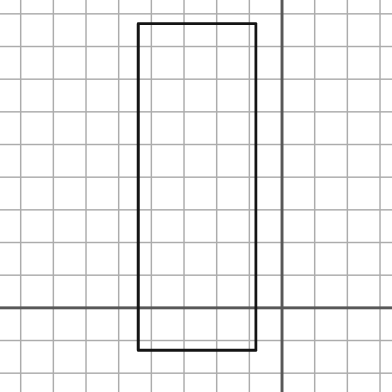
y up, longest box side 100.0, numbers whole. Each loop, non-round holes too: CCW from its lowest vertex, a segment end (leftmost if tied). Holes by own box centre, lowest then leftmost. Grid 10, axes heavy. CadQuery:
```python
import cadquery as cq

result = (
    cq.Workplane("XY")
    .moveTo(-44.0, -13.0)
    .lineTo(-8.0, -13.0)
    .lineTo(-8.0, 87.0)
    .lineTo(-44.0, 87.0)
    .close()
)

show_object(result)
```